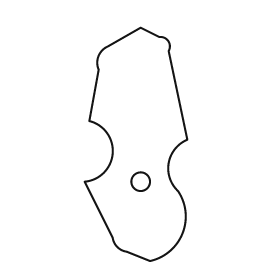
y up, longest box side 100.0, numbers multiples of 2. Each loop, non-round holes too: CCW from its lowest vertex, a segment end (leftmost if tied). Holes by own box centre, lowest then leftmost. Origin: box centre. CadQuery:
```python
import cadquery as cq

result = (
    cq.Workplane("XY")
    .moveTo(6.0, -50.0)
    .threePointArc((20.0, -38.0), (18.0, -20.0))
    .threePointArc((14.0, -8.0), (22.0, 2.0))
    .lineTo(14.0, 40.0)
    .threePointArc((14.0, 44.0), (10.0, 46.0))
    .lineTo(2.0, 50.0)
    .lineTo(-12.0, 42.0)
    .threePointArc((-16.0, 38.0), (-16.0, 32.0))
    .lineTo(-20.0, 10.0)
    .threePointArc((-10.0, -4.0), (-22.0, -16.0))
    .lineTo(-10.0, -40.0)
    .threePointArc((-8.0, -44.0), (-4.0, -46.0))
    .close()
    .moveTo(2.0, -16.0)
    .circle(4.0)
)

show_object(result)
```